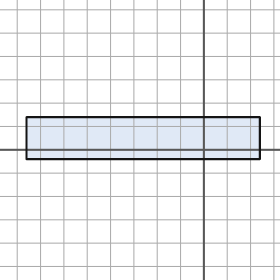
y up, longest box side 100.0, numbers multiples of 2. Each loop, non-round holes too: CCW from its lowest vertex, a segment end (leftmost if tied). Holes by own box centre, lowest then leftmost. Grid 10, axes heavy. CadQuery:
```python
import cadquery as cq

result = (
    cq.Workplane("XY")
    .moveTo(-76.0, -4.0)
    .lineTo(24.0, -4.0)
    .lineTo(24.0, 14.0)
    .lineTo(-76.0, 14.0)
    .close()
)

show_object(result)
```